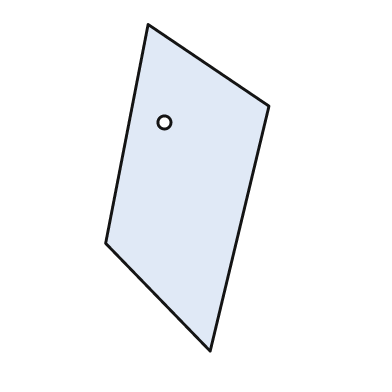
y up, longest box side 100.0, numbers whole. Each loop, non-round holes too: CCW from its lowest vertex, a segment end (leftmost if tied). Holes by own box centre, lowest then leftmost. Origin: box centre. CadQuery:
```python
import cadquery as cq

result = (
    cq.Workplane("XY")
    .moveTo(7.0, -50.0)
    .lineTo(25.0, 25.0)
    .lineTo(-12.0, 50.0)
    .lineTo(-25.0, -17.0)
    .close()
    .moveTo(-7.0, 20.0)
    .circle(2.0)
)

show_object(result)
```